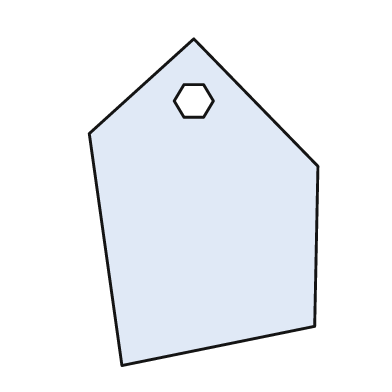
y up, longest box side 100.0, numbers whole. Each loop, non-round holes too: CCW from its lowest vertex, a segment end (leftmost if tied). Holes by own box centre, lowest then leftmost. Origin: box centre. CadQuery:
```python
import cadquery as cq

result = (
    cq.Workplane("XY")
    .moveTo(-25.0, -50.0)
    .lineTo(34.0, -38.0)
    .lineTo(35.0, 11.0)
    .lineTo(-3.0, 50.0)
    .lineTo(-35.0, 21.0)
    .close()
    .moveTo(-6.0, 26.0)
    .lineTo(0.0, 26.0)
    .lineTo(3.0, 31.0)
    .lineTo(0.0, 36.0)
    .lineTo(-6.0, 36.0)
    .lineTo(-9.0, 31.0)
    .close()
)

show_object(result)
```